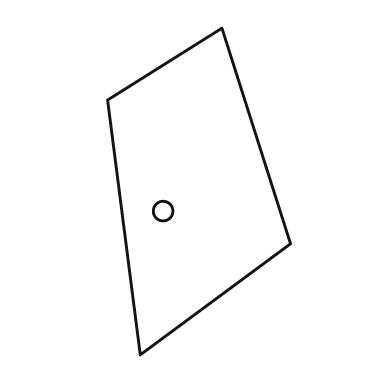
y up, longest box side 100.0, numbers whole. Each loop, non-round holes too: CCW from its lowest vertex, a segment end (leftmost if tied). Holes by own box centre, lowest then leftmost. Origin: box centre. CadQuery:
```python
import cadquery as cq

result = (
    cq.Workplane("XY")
    .moveTo(-18.0, -50.0)
    .lineTo(28.0, -16.0)
    .lineTo(7.0, 50.0)
    .lineTo(-28.0, 28.0)
    .close()
    .moveTo(-11.0, -6.0)
    .circle(3.0)
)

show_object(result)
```